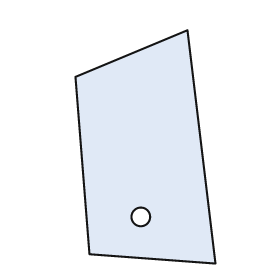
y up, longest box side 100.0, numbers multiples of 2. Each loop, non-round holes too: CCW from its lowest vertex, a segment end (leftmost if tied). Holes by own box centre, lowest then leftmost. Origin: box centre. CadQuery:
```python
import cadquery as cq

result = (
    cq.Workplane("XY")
    .moveTo(30.0, -50.0)
    .lineTo(18.0, 50.0)
    .lineTo(-30.0, 30.0)
    .lineTo(-24.0, -46.0)
    .close()
    .moveTo(-2.0, -30.0)
    .circle(4.0)
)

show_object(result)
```